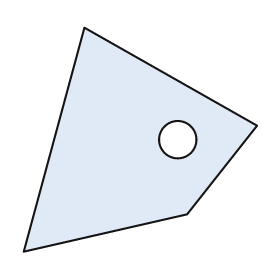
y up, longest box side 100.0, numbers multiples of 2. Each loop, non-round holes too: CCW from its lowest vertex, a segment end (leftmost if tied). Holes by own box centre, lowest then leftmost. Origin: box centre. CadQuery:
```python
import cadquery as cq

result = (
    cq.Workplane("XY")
    .moveTo(-50.0, -48.0)
    .lineTo(20.0, -32.0)
    .lineTo(50.0, 6.0)
    .lineTo(-24.0, 48.0)
    .close()
    .moveTo(16.0, 0.0)
    .circle(8.0)
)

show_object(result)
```